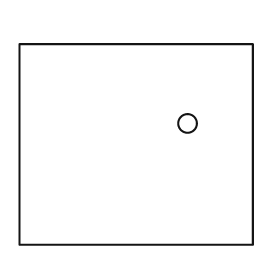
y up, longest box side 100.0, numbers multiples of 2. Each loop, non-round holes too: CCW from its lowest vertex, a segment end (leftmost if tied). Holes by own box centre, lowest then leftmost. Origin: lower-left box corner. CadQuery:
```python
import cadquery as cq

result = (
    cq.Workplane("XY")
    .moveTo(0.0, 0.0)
    .lineTo(100.0, 0.0)
    .lineTo(100.0, 86.0)
    .lineTo(0.0, 86.0)
    .close()
    .moveTo(72.0, 52.0)
    .circle(4.0)
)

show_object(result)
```